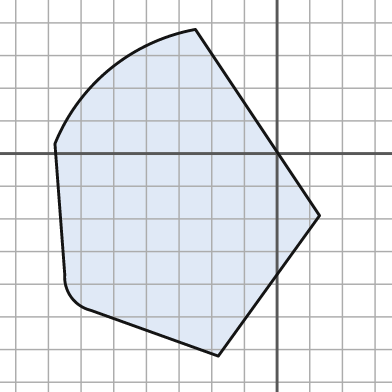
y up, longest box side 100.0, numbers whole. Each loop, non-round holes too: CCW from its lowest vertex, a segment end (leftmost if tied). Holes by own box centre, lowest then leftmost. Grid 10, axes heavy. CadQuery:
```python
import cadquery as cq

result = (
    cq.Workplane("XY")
    .moveTo(-18.0, -62.0)
    .lineTo(13.0, -19.0)
    .lineTo(-25.0, 38.0)
    .threePointArc((-51.0, 26.0), (-68.0, 3.0))
    .lineTo(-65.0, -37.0)
    .threePointArc((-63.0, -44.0), (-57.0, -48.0))
    .close()
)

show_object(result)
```